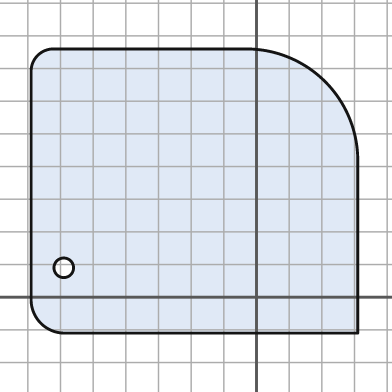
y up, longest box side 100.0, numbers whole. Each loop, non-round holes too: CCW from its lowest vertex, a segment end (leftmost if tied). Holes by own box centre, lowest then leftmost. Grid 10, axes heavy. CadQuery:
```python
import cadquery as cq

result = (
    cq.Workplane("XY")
    .moveTo(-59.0, -11.0)
    .lineTo(31.0, -11.0)
    .lineTo(31.0, 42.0)
    .threePointArc((21.0, 66.0), (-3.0, 76.0))
    .lineTo(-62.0, 76.0)
    .threePointArc((-67.0, 74.0), (-69.0, 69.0))
    .lineTo(-69.0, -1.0)
    .threePointArc((-66.0, -8.0), (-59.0, -11.0))
    .close()
    .moveTo(-59.0, 9.0)
    .circle(3.0)
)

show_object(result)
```